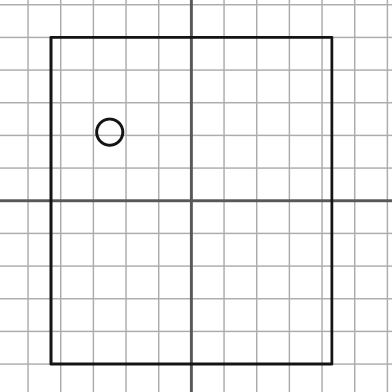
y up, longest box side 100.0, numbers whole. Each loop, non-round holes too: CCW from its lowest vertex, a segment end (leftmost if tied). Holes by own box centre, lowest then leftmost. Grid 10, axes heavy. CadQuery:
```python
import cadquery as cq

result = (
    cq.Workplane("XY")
    .moveTo(-43.0, -50.0)
    .lineTo(43.0, -50.0)
    .lineTo(43.0, 50.0)
    .lineTo(-43.0, 50.0)
    .close()
    .moveTo(-25.0, 21.0)
    .circle(4.0)
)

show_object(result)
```